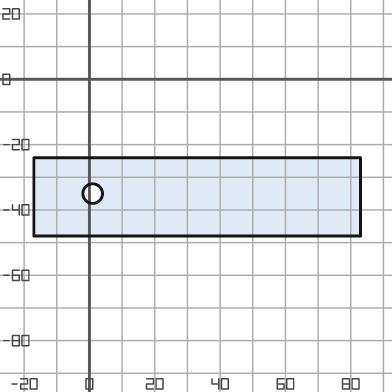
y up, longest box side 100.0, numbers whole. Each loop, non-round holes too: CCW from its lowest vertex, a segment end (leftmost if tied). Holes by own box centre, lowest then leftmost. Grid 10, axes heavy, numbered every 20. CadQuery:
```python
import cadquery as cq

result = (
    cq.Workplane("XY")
    .moveTo(-17.0, -48.0)
    .lineTo(83.0, -48.0)
    .lineTo(83.0, -24.0)
    .lineTo(-17.0, -24.0)
    .close()
    .moveTo(1.0, -35.0)
    .circle(3.0)
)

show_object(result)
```